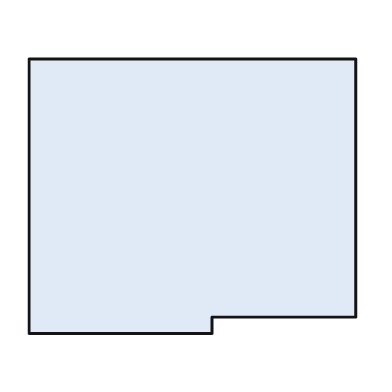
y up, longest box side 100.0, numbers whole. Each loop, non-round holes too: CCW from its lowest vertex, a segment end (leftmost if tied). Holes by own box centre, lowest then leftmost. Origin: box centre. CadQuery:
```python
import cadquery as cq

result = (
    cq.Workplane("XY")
    .moveTo(-50.0, -42.0)
    .lineTo(6.0, -42.0)
    .lineTo(6.0, -37.0)
    .lineTo(50.0, -37.0)
    .lineTo(50.0, 42.0)
    .lineTo(-50.0, 42.0)
    .close()
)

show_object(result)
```